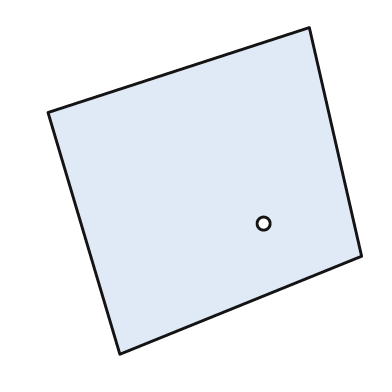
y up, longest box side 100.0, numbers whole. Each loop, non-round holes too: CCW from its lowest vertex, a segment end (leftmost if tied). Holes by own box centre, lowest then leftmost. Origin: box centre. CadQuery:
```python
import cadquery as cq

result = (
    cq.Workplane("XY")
    .moveTo(-26.0, -50.0)
    .lineTo(48.0, -20.0)
    .lineTo(32.0, 50.0)
    .lineTo(-48.0, 24.0)
    .close()
    .moveTo(18.0, -10.0)
    .circle(2.0)
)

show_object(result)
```